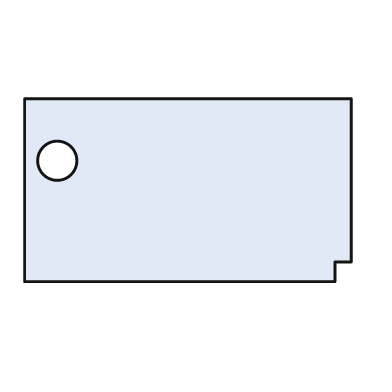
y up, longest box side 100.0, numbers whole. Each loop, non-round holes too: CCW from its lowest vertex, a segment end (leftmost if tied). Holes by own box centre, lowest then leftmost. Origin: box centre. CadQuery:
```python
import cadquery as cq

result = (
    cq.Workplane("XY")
    .moveTo(-50.0, -28.0)
    .lineTo(45.0, -28.0)
    .lineTo(45.0, -22.0)
    .lineTo(50.0, -22.0)
    .lineTo(50.0, 28.0)
    .lineTo(-50.0, 28.0)
    .close()
    .moveTo(-40.0, 9.0)
    .circle(6.0)
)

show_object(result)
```